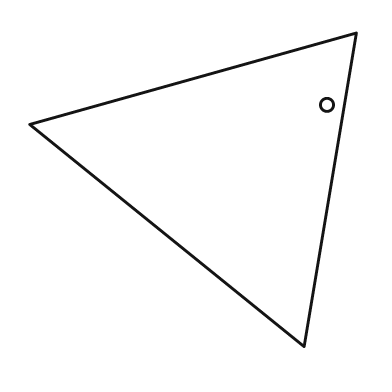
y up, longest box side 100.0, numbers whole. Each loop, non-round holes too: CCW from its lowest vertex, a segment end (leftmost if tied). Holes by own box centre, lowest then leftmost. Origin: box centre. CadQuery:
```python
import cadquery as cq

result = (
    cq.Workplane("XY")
    .moveTo(34.0, -48.0)
    .lineTo(50.0, 48.0)
    .lineTo(-50.0, 20.0)
    .close()
    .moveTo(41.0, 26.0)
    .circle(2.0)
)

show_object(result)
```